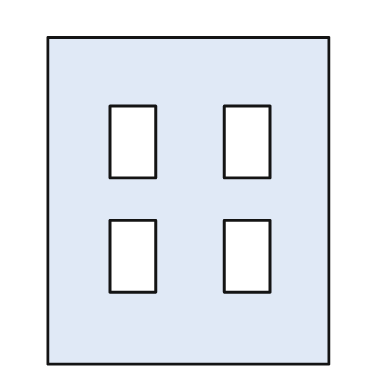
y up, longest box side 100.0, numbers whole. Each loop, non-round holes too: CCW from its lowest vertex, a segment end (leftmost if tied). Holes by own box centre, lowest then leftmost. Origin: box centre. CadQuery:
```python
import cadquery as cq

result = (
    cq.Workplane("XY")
    .moveTo(-43.0, -50.0)
    .lineTo(43.0, -50.0)
    .lineTo(43.0, 50.0)
    .lineTo(-43.0, 50.0)
    .close()
    .moveTo(-24.0, -28.0)
    .lineTo(-10.0, -28.0)
    .lineTo(-10.0, -6.0)
    .lineTo(-24.0, -6.0)
    .close()
    .moveTo(11.0, -28.0)
    .lineTo(25.0, -28.0)
    .lineTo(25.0, -6.0)
    .lineTo(11.0, -6.0)
    .close()
    .moveTo(-24.0, 7.0)
    .lineTo(-10.0, 7.0)
    .lineTo(-10.0, 29.0)
    .lineTo(-24.0, 29.0)
    .close()
    .moveTo(11.0, 7.0)
    .lineTo(25.0, 7.0)
    .lineTo(25.0, 29.0)
    .lineTo(11.0, 29.0)
    .close()
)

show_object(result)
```